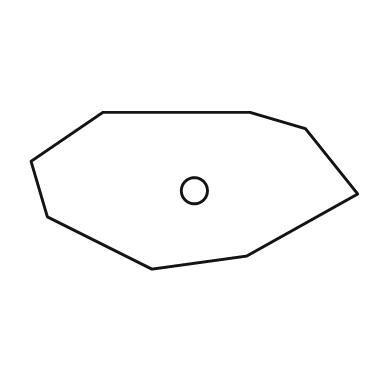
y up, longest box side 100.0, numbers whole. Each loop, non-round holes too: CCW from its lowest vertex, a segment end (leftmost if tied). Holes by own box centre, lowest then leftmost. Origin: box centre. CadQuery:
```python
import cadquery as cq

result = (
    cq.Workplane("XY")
    .moveTo(-13.0, -24.0)
    .lineTo(16.0, -20.0)
    .lineTo(50.0, -1.0)
    .lineTo(34.0, 19.0)
    .lineTo(17.0, 24.0)
    .lineTo(-28.0, 24.0)
    .lineTo(-50.0, 9.0)
    .lineTo(-45.0, -8.0)
    .close()
    .moveTo(0.0, 0.0)
    .circle(4.0)
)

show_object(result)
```